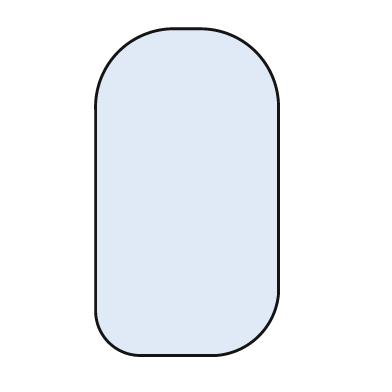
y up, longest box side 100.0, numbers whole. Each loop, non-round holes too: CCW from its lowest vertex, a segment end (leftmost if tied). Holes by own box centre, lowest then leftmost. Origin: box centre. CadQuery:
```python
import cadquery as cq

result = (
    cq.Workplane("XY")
    .moveTo(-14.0, -50.0)
    .lineTo(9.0, -50.0)
    .threePointArc((22.0, -44.0), (28.0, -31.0))
    .lineTo(28.0, 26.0)
    .threePointArc((21.0, 43.0), (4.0, 50.0))
    .lineTo(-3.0, 50.0)
    .threePointArc((-21.0, 43.0), (-28.0, 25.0))
    .lineTo(-28.0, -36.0)
    .threePointArc((-24.0, -46.0), (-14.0, -50.0))
    .close()
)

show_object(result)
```